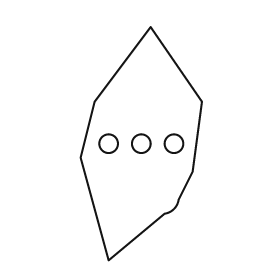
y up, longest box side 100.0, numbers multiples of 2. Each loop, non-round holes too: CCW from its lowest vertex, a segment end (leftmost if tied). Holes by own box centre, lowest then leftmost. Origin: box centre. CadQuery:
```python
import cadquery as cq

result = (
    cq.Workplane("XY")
    .moveTo(-14.0, -50.0)
    .lineTo(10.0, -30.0)
    .threePointArc((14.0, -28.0), (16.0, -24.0))
    .lineTo(22.0, -12.0)
    .lineTo(26.0, 18.0)
    .lineTo(4.0, 50.0)
    .lineTo(-20.0, 18.0)
    .lineTo(-26.0, -6.0)
    .close()
    .moveTo(-14.0, 0.0)
    .circle(4.0)
    .moveTo(0.0, 0.0)
    .circle(4.0)
    .moveTo(14.0, 0.0)
    .circle(4.0)
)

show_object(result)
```